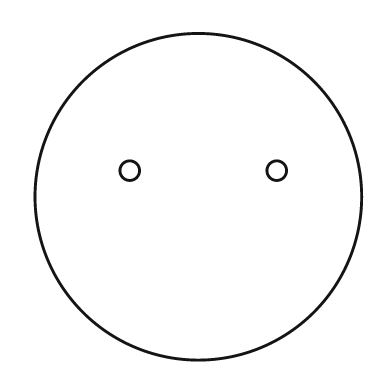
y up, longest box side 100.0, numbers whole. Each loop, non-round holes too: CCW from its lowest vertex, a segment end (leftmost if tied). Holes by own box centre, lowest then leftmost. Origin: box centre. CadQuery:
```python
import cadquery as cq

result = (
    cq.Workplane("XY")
    .moveTo(0.0, 0.0)
    .circle(50.0)
    .moveTo(-21.0, 8.0)
    .circle(3.0)
    .moveTo(24.0, 8.0)
    .circle(3.0)
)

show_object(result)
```